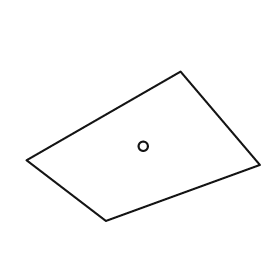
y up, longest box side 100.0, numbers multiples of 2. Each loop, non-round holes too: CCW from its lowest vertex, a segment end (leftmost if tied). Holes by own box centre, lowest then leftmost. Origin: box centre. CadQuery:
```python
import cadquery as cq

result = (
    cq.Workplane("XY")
    .moveTo(-16.0, -32.0)
    .lineTo(50.0, -8.0)
    .lineTo(16.0, 32.0)
    .lineTo(-50.0, -6.0)
    .close()
    .moveTo(0.0, 0.0)
    .circle(2.0)
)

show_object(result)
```